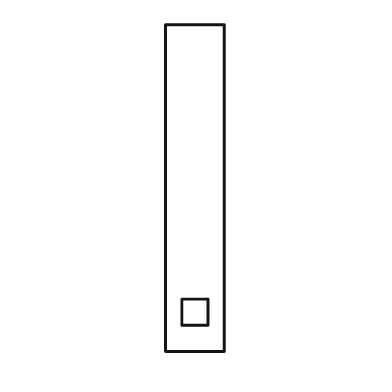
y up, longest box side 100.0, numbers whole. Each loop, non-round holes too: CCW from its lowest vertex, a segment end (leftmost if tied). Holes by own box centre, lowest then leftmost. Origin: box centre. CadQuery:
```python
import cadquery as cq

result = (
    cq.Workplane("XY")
    .moveTo(-9.0, -50.0)
    .lineTo(9.0, -50.0)
    .lineTo(9.0, 50.0)
    .lineTo(-9.0, 50.0)
    .close()
    .moveTo(-4.0, -42.0)
    .lineTo(4.0, -42.0)
    .lineTo(4.0, -34.0)
    .lineTo(-4.0, -34.0)
    .close()
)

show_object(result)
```